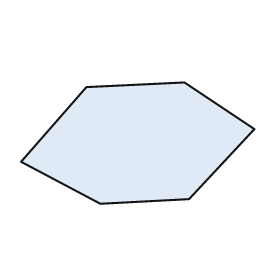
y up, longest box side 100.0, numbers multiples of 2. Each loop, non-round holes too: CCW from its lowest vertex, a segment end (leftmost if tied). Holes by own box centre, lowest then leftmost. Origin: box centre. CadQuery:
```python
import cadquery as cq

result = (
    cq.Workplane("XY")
    .moveTo(-16.0, -26.0)
    .lineTo(22.0, -24.0)
    .lineTo(50.0, 6.0)
    .lineTo(20.0, 26.0)
    .lineTo(-22.0, 24.0)
    .lineTo(-50.0, -8.0)
    .close()
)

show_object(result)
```